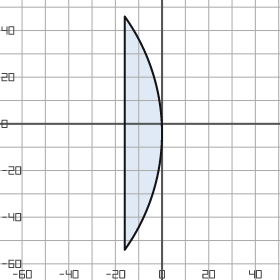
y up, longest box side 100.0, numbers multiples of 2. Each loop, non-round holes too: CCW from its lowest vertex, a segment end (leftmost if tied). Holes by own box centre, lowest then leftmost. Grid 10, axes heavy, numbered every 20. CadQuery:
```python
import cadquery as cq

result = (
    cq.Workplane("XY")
    .moveTo(-16.0, -54.0)
    .threePointArc((0.0, -4.0), (-16.0, 46.0))
    .close()
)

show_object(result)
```